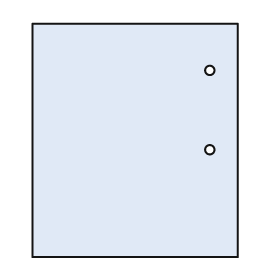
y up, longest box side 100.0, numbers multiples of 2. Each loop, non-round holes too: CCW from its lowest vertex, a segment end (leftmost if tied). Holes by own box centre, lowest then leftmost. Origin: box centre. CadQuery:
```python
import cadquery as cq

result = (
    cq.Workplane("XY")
    .moveTo(-44.0, -50.0)
    .lineTo(44.0, -50.0)
    .lineTo(44.0, 50.0)
    .lineTo(-44.0, 50.0)
    .close()
    .moveTo(32.0, -4.0)
    .circle(2.0)
    .moveTo(32.0, 30.0)
    .circle(2.0)
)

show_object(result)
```